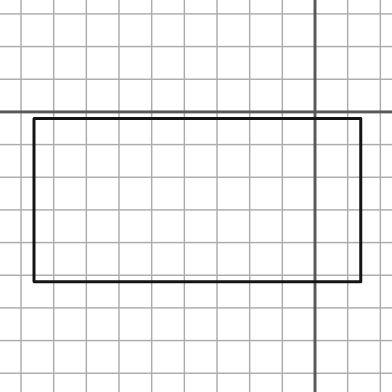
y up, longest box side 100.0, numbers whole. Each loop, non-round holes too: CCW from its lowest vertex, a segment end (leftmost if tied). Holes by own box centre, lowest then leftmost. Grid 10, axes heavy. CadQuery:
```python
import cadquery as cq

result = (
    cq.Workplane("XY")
    .moveTo(-86.0, -52.0)
    .lineTo(14.0, -52.0)
    .lineTo(14.0, -2.0)
    .lineTo(-86.0, -2.0)
    .close()
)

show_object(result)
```